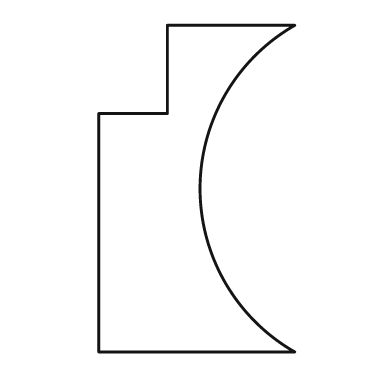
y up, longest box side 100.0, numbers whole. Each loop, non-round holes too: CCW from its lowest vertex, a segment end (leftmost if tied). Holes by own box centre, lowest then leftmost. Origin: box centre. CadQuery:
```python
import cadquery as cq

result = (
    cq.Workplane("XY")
    .moveTo(-30.0, -50.0)
    .lineTo(30.0, -50.0)
    .threePointArc((1.0, 0.0), (30.0, 50.0))
    .lineTo(-9.0, 50.0)
    .lineTo(-9.0, 23.0)
    .lineTo(-30.0, 23.0)
    .close()
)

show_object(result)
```